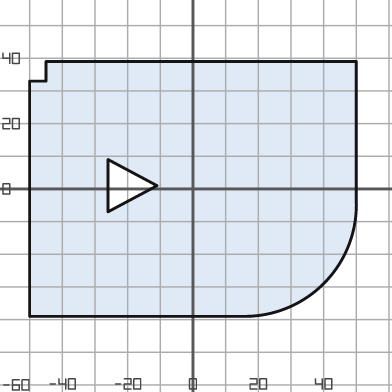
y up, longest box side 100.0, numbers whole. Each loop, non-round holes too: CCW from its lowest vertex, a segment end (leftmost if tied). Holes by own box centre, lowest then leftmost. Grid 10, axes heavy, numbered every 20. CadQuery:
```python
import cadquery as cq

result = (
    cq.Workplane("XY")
    .moveTo(-50.0, -39.0)
    .lineTo(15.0, -39.0)
    .threePointArc((40.0, -29.0), (50.0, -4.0))
    .lineTo(50.0, 39.0)
    .lineTo(-45.0, 39.0)
    .lineTo(-45.0, 33.0)
    .lineTo(-50.0, 33.0)
    .close()
    .moveTo(-26.0, -7.0)
    .lineTo(-11.0, 1.0)
    .lineTo(-26.0, 9.0)
    .close()
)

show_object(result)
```